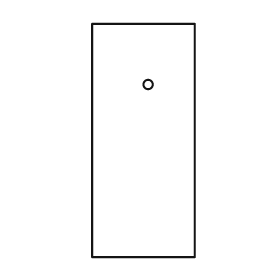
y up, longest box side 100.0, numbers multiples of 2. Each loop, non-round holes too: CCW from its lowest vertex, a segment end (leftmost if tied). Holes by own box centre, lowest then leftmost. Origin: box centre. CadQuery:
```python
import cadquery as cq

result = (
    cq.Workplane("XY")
    .moveTo(-22.0, -50.0)
    .lineTo(22.0, -50.0)
    .lineTo(22.0, 50.0)
    .lineTo(-22.0, 50.0)
    .close()
    .moveTo(2.0, 24.0)
    .circle(2.0)
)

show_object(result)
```